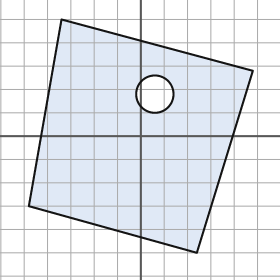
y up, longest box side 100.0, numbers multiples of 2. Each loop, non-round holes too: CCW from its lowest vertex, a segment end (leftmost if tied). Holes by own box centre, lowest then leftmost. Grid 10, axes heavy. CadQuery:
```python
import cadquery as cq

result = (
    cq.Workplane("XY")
    .moveTo(24.0, -50.0)
    .lineTo(48.0, 28.0)
    .lineTo(-34.0, 50.0)
    .lineTo(-48.0, -30.0)
    .close()
    .moveTo(6.0, 18.0)
    .circle(8.0)
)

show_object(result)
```